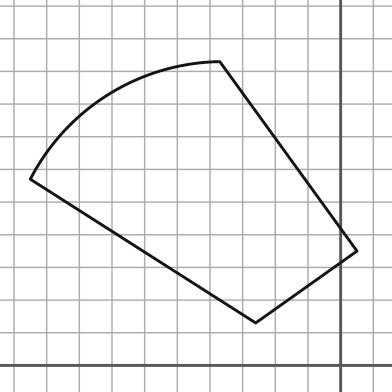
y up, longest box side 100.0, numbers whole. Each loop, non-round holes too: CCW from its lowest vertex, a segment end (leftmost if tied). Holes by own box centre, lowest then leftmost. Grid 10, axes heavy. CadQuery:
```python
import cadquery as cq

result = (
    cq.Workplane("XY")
    .moveTo(-26.0, 13.0)
    .lineTo(5.0, 35.0)
    .lineTo(-37.0, 93.0)
    .threePointArc((-71.0, 83.0), (-95.0, 57.0))
    .close()
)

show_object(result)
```